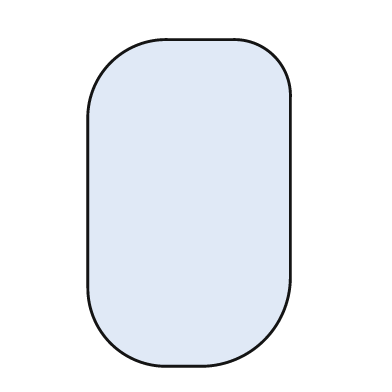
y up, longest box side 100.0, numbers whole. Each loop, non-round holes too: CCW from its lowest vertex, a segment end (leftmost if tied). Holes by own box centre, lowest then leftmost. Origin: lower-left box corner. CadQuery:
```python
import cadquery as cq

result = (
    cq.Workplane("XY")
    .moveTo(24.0, 0.0)
    .lineTo(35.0, 0.0)
    .threePointArc((54.0, 8.0), (62.0, 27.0))
    .lineTo(62.0, 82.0)
    .threePointArc((57.0, 95.0), (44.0, 100.0))
    .lineTo(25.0, 100.0)
    .threePointArc((7.0, 93.0), (0.0, 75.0))
    .lineTo(0.0, 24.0)
    .threePointArc((7.0, 7.0), (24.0, 0.0))
    .close()
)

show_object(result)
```